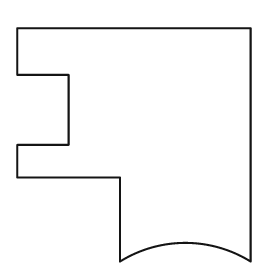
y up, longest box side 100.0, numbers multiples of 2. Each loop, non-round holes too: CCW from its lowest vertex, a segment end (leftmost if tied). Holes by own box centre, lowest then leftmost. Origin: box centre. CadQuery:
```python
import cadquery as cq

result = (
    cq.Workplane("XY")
    .moveTo(-6.0, -50.0)
    .threePointArc((22.0, -42.0), (50.0, -50.0))
    .lineTo(50.0, 50.0)
    .lineTo(-50.0, 50.0)
    .lineTo(-50.0, 30.0)
    .lineTo(-28.0, 30.0)
    .lineTo(-28.0, 0.0)
    .lineTo(-50.0, 0.0)
    .lineTo(-50.0, -14.0)
    .lineTo(-6.0, -14.0)
    .close()
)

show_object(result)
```